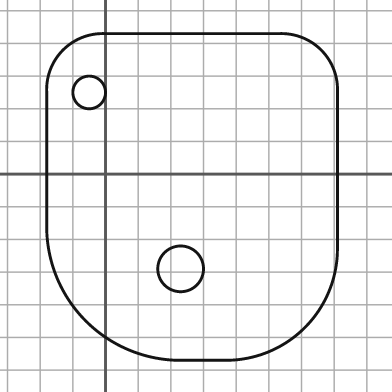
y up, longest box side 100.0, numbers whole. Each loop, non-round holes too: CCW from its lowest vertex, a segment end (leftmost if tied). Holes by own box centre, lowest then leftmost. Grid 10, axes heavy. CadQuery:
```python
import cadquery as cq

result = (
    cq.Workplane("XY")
    .moveTo(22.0, -57.0)
    .lineTo(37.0, -57.0)
    .threePointArc((61.0, -47.0), (71.0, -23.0))
    .lineTo(71.0, 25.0)
    .threePointArc((66.0, 38.0), (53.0, 43.0))
    .lineTo(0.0, 43.0)
    .threePointArc((-13.0, 38.0), (-18.0, 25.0))
    .lineTo(-18.0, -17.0)
    .threePointArc((-6.0, -45.0), (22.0, -57.0))
    .close()
    .moveTo(23.0, -29.0)
    .circle(7.0)
    .moveTo(-5.0, 25.0)
    .circle(5.0)
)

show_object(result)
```